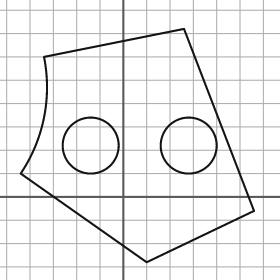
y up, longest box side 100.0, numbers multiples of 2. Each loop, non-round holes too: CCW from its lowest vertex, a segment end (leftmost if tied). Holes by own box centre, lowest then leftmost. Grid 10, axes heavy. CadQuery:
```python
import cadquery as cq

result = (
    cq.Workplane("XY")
    .moveTo(10.0, -28.0)
    .lineTo(56.0, -6.0)
    .lineTo(26.0, 72.0)
    .lineTo(-34.0, 60.0)
    .threePointArc((-34.0, 34.0), (-44.0, 10.0))
    .close()
    .moveTo(-14.0, 22.0)
    .circle(12.0)
    .moveTo(28.0, 22.0)
    .circle(12.0)
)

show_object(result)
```